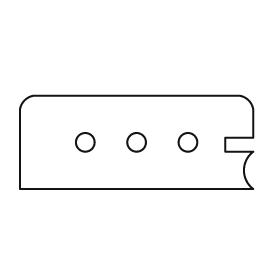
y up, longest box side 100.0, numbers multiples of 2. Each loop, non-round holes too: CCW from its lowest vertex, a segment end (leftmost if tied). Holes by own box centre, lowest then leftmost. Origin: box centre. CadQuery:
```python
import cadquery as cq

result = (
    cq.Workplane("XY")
    .moveTo(-50.0, -20.0)
    .lineTo(50.0, -20.0)
    .threePointArc((46.0, -12.0), (50.0, -4.0))
    .lineTo(38.0, -4.0)
    .lineTo(38.0, 2.0)
    .lineTo(50.0, 2.0)
    .lineTo(50.0, 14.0)
    .threePointArc((48.0, 18.0), (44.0, 20.0))
    .lineTo(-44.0, 20.0)
    .threePointArc((-48.0, 18.0), (-50.0, 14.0))
    .close()
    .moveTo(-22.0, 0.0)
    .circle(4.0)
    .moveTo(0.0, 0.0)
    .circle(4.0)
    .moveTo(22.0, 0.0)
    .circle(4.0)
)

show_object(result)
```